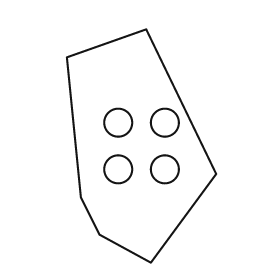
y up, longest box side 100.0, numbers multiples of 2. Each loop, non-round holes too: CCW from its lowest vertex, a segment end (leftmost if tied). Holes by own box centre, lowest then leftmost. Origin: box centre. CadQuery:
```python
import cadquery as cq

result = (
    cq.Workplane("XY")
    .moveTo(4.0, -50.0)
    .lineTo(32.0, -12.0)
    .lineTo(2.0, 50.0)
    .lineTo(-32.0, 38.0)
    .lineTo(-26.0, -22.0)
    .lineTo(-18.0, -38.0)
    .close()
    .moveTo(-10.0, -10.0)
    .circle(6.0)
    .moveTo(10.0, -10.0)
    .circle(6.0)
    .moveTo(-10.0, 10.0)
    .circle(6.0)
    .moveTo(10.0, 10.0)
    .circle(6.0)
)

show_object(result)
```